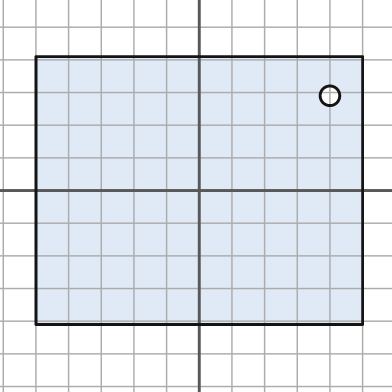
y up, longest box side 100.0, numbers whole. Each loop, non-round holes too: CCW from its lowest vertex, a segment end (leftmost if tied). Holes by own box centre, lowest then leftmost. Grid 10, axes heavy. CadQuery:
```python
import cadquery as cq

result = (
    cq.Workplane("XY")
    .moveTo(-50.0, -41.0)
    .lineTo(50.0, -41.0)
    .lineTo(50.0, 41.0)
    .lineTo(-50.0, 41.0)
    .close()
    .moveTo(40.0, 29.0)
    .circle(3.0)
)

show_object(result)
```